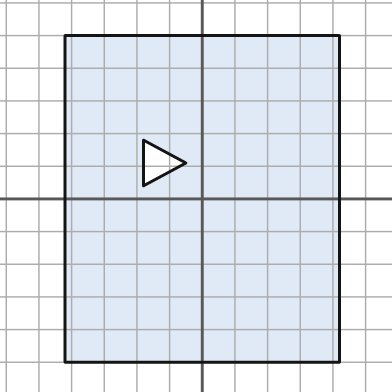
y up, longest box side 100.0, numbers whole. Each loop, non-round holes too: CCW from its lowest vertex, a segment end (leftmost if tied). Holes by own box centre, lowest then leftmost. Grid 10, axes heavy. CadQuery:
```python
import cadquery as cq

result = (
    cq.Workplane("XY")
    .moveTo(-42.0, -50.0)
    .lineTo(42.0, -50.0)
    .lineTo(42.0, 50.0)
    .lineTo(-42.0, 50.0)
    .close()
    .moveTo(-18.0, 4.0)
    .lineTo(-5.0, 11.0)
    .lineTo(-18.0, 18.0)
    .close()
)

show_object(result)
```